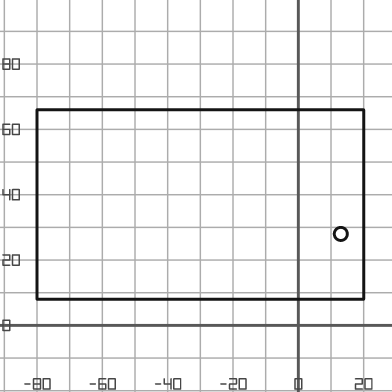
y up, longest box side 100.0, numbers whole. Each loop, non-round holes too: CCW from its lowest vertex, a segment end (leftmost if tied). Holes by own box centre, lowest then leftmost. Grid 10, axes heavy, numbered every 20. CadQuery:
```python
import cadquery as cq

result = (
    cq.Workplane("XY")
    .moveTo(-80.0, 8.0)
    .lineTo(20.0, 8.0)
    .lineTo(20.0, 66.0)
    .lineTo(-80.0, 66.0)
    .close()
    .moveTo(13.0, 28.0)
    .circle(2.0)
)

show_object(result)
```